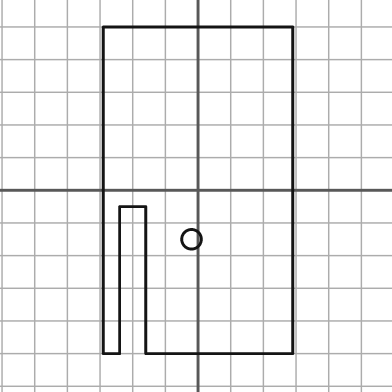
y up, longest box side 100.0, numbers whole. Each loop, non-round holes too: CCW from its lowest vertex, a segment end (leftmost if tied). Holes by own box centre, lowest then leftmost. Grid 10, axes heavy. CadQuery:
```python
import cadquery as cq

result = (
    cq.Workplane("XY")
    .moveTo(-29.0, -50.0)
    .lineTo(-24.0, -50.0)
    .lineTo(-24.0, -5.0)
    .lineTo(-16.0, -5.0)
    .lineTo(-16.0, -50.0)
    .lineTo(29.0, -50.0)
    .lineTo(29.0, 50.0)
    .lineTo(-29.0, 50.0)
    .close()
    .moveTo(-2.0, -15.0)
    .circle(3.0)
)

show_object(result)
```